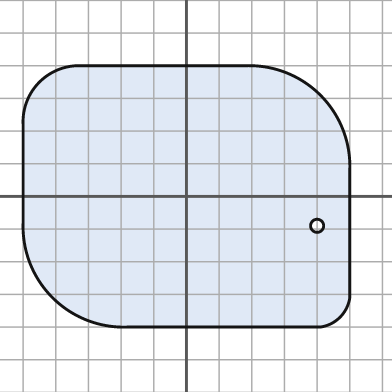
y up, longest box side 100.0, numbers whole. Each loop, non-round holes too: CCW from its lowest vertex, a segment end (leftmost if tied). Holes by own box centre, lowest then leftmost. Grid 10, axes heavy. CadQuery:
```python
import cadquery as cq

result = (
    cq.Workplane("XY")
    .moveTo(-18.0, -40.0)
    .lineTo(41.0, -40.0)
    .threePointArc((47.0, -37.0), (50.0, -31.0))
    .lineTo(50.0, 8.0)
    .threePointArc((41.0, 31.0), (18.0, 40.0))
    .lineTo(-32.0, 40.0)
    .threePointArc((-45.0, 35.0), (-50.0, 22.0))
    .lineTo(-50.0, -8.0)
    .threePointArc((-41.0, -31.0), (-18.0, -40.0))
    .close()
    .moveTo(40.0, -9.0)
    .circle(2.0)
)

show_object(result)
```